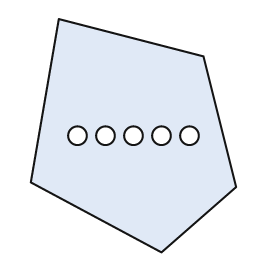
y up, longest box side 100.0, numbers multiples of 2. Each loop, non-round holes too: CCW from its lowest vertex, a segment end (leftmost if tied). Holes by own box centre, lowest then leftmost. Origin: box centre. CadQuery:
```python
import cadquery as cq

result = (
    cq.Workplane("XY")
    .moveTo(12.0, -50.0)
    .lineTo(44.0, -22.0)
    .lineTo(30.0, 34.0)
    .lineTo(-32.0, 50.0)
    .lineTo(-44.0, -20.0)
    .close()
    .moveTo(-24.0, 0.0)
    .circle(4.0)
    .moveTo(-12.0, 0.0)
    .circle(4.0)
    .moveTo(0.0, 0.0)
    .circle(4.0)
    .moveTo(12.0, 0.0)
    .circle(4.0)
    .moveTo(24.0, 0.0)
    .circle(4.0)
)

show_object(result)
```